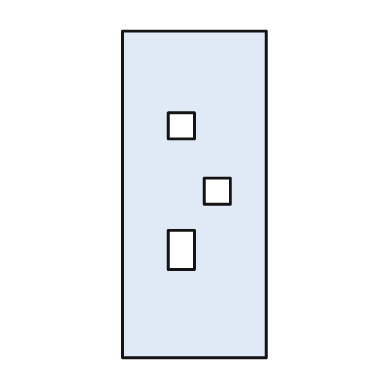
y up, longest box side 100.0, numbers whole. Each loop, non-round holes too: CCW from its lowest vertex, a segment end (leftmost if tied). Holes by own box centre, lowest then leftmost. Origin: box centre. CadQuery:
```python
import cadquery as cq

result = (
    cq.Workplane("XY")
    .moveTo(-22.0, -50.0)
    .lineTo(22.0, -50.0)
    .lineTo(22.0, 50.0)
    .lineTo(-22.0, 50.0)
    .close()
    .moveTo(-8.0, -23.0)
    .lineTo(0.0, -23.0)
    .lineTo(0.0, -11.0)
    .lineTo(-8.0, -11.0)
    .close()
    .moveTo(3.0, -3.0)
    .lineTo(11.0, -3.0)
    .lineTo(11.0, 5.0)
    .lineTo(3.0, 5.0)
    .close()
    .moveTo(-8.0, 17.0)
    .lineTo(0.0, 17.0)
    .lineTo(0.0, 25.0)
    .lineTo(-8.0, 25.0)
    .close()
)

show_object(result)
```